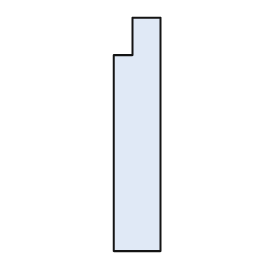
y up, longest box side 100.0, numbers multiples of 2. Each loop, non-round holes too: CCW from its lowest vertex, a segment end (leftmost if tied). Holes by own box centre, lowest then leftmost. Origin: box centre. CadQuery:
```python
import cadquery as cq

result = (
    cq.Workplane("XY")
    .moveTo(-10.0, -50.0)
    .lineTo(10.0, -50.0)
    .lineTo(10.0, 50.0)
    .lineTo(-2.0, 50.0)
    .lineTo(-2.0, 34.0)
    .lineTo(-10.0, 34.0)
    .close()
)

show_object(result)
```